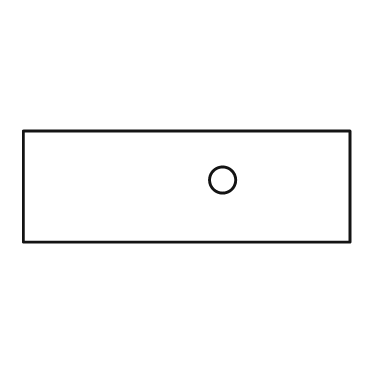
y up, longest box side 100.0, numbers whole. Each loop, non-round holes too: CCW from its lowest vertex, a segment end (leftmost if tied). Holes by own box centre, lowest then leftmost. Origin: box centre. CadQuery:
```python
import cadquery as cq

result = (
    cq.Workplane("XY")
    .moveTo(-50.0, -17.0)
    .lineTo(50.0, -17.0)
    .lineTo(50.0, 17.0)
    .lineTo(-50.0, 17.0)
    .close()
    .moveTo(11.0, 2.0)
    .circle(4.0)
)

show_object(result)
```